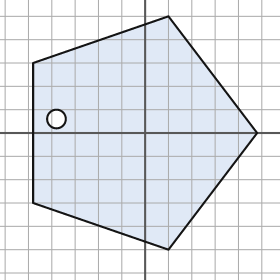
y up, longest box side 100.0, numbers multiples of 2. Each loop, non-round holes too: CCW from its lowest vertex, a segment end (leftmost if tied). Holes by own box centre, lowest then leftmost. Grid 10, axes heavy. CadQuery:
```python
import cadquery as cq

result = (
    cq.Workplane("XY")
    .moveTo(10.0, -50.0)
    .lineTo(48.0, 0.0)
    .lineTo(10.0, 50.0)
    .lineTo(-48.0, 30.0)
    .lineTo(-48.0, -30.0)
    .close()
    .moveTo(-38.0, 6.0)
    .circle(4.0)
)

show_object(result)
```